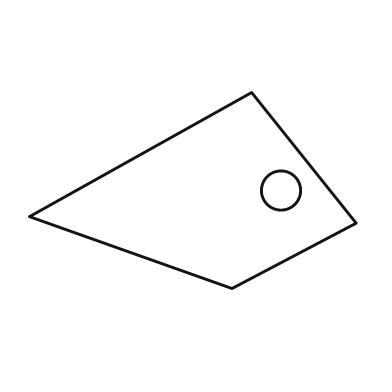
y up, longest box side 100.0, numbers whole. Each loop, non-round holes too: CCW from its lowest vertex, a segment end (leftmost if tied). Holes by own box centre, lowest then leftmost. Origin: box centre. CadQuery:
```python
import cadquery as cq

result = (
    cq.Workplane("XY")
    .moveTo(12.0, -30.0)
    .lineTo(50.0, -10.0)
    .lineTo(18.0, 30.0)
    .lineTo(-50.0, -8.0)
    .close()
    .moveTo(27.0, 0.0)
    .circle(6.0)
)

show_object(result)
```